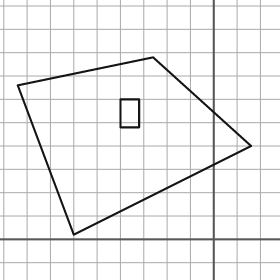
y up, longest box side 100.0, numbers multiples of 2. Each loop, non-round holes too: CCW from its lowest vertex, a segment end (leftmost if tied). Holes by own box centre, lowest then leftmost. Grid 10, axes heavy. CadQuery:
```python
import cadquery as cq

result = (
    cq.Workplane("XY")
    .moveTo(-60.0, 2.0)
    .lineTo(16.0, 40.0)
    .lineTo(-26.0, 78.0)
    .lineTo(-84.0, 66.0)
    .close()
    .moveTo(-40.0, 48.0)
    .lineTo(-32.0, 48.0)
    .lineTo(-32.0, 60.0)
    .lineTo(-40.0, 60.0)
    .close()
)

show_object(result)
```